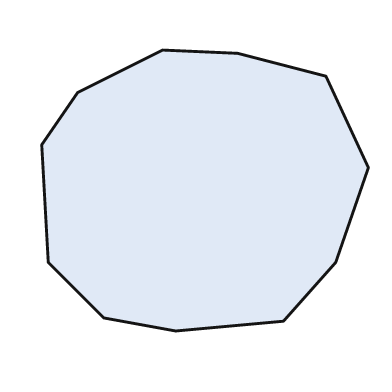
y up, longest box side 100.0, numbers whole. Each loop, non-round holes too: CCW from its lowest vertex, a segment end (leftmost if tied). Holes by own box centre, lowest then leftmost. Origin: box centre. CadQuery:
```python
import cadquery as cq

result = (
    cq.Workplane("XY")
    .moveTo(-9.0, -43.0)
    .lineTo(24.0, -40.0)
    .lineTo(40.0, -22.0)
    .lineTo(50.0, 7.0)
    .lineTo(37.0, 35.0)
    .lineTo(10.0, 42.0)
    .lineTo(-13.0, 43.0)
    .lineTo(-39.0, 30.0)
    .lineTo(-50.0, 14.0)
    .lineTo(-48.0, -22.0)
    .lineTo(-31.0, -39.0)
    .close()
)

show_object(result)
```